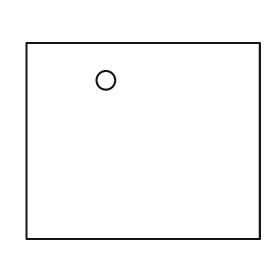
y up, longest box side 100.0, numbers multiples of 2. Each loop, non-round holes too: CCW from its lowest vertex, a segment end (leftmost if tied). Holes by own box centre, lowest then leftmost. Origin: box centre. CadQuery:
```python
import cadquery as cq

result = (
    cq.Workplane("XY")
    .moveTo(-50.0, -42.0)
    .lineTo(50.0, -42.0)
    .lineTo(50.0, 42.0)
    .lineTo(-50.0, 42.0)
    .close()
    .moveTo(-16.0, 26.0)
    .circle(4.0)
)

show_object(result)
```